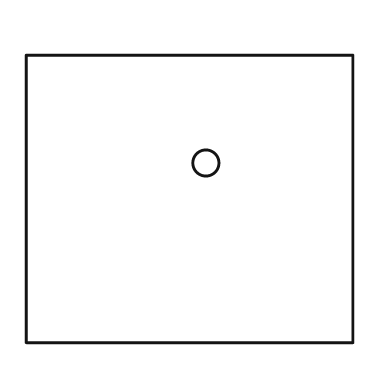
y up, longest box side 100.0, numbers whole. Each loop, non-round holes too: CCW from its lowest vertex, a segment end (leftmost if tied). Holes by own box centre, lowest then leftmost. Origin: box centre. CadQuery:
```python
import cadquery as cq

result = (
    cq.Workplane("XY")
    .moveTo(-50.0, -44.0)
    .lineTo(50.0, -44.0)
    .lineTo(50.0, 44.0)
    .lineTo(-50.0, 44.0)
    .close()
    .moveTo(5.0, 11.0)
    .circle(4.0)
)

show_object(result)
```